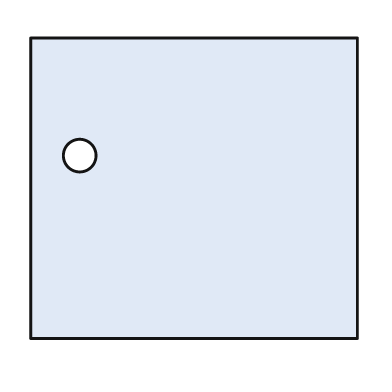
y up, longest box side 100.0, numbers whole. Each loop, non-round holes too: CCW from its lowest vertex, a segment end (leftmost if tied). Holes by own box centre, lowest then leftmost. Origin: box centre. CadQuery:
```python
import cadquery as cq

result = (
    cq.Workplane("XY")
    .moveTo(-50.0, -46.0)
    .lineTo(50.0, -46.0)
    .lineTo(50.0, 46.0)
    .lineTo(-50.0, 46.0)
    .close()
    .moveTo(-35.0, 10.0)
    .circle(5.0)
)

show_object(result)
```